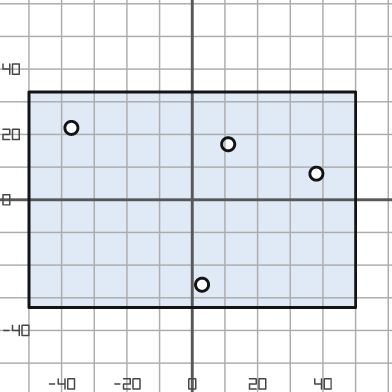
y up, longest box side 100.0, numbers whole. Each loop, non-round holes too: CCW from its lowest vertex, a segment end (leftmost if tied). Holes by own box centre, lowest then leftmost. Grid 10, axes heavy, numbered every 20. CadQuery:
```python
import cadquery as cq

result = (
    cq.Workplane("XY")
    .moveTo(-50.0, -33.0)
    .lineTo(50.0, -33.0)
    .lineTo(50.0, 33.0)
    .lineTo(-50.0, 33.0)
    .close()
    .moveTo(3.0, -26.0)
    .circle(2.0)
    .moveTo(38.0, 8.0)
    .circle(2.0)
    .moveTo(11.0, 17.0)
    .circle(2.0)
    .moveTo(-37.0, 22.0)
    .circle(2.0)
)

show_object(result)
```